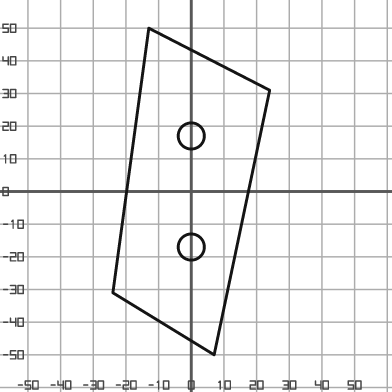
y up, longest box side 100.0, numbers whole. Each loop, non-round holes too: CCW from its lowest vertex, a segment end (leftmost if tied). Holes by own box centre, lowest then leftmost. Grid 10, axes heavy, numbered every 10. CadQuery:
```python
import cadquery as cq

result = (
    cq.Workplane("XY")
    .moveTo(7.0, -50.0)
    .lineTo(24.0, 31.0)
    .lineTo(-13.0, 50.0)
    .lineTo(-24.0, -31.0)
    .close()
    .moveTo(0.0, -17.0)
    .circle(4.0)
    .moveTo(0.0, 17.0)
    .circle(4.0)
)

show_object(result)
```